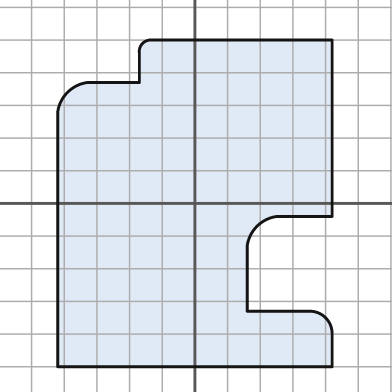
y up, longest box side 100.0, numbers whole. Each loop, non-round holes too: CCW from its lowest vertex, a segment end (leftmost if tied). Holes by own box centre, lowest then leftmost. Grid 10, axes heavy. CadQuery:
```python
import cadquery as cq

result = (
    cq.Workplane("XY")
    .moveTo(-42.0, -50.0)
    .lineTo(42.0, -50.0)
    .lineTo(42.0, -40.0)
    .threePointArc((40.0, -35.0), (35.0, -33.0))
    .lineTo(16.0, -33.0)
    .lineTo(16.0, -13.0)
    .threePointArc((19.0, -7.0), (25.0, -4.0))
    .lineTo(42.0, -4.0)
    .lineTo(42.0, 50.0)
    .lineTo(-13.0, 50.0)
    .threePointArc((-16.0, 49.0), (-17.0, 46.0))
    .lineTo(-17.0, 37.0)
    .lineTo(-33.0, 37.0)
    .threePointArc((-39.0, 34.0), (-42.0, 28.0))
    .close()
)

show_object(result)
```